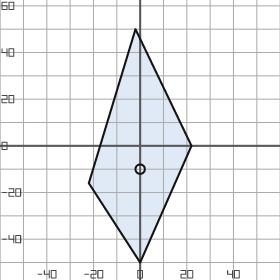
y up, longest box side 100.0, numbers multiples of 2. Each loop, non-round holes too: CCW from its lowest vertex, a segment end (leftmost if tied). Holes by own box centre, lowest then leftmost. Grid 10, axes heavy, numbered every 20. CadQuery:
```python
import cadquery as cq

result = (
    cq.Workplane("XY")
    .moveTo(0.0, -50.0)
    .lineTo(22.0, 0.0)
    .lineTo(-2.0, 50.0)
    .lineTo(-22.0, -16.0)
    .close()
    .moveTo(0.0, -10.0)
    .circle(2.0)
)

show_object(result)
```